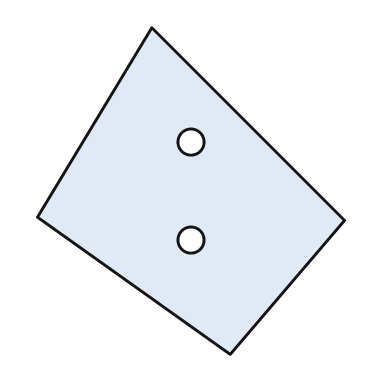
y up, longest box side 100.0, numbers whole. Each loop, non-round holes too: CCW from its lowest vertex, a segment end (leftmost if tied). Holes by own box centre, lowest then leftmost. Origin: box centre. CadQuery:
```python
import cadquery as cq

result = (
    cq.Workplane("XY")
    .moveTo(12.0, -50.0)
    .lineTo(47.0, -9.0)
    .lineTo(-12.0, 50.0)
    .lineTo(-47.0, -8.0)
    .close()
    .moveTo(0.0, -15.0)
    .circle(4.0)
    .moveTo(0.0, 15.0)
    .circle(4.0)
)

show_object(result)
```